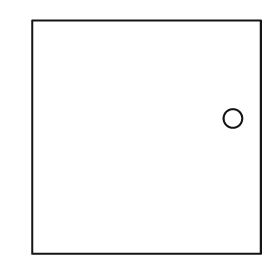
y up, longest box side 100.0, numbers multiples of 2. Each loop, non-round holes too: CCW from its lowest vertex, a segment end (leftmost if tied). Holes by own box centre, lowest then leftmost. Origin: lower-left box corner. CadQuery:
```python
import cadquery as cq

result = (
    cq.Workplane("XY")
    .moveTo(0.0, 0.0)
    .lineTo(98.0, 0.0)
    .lineTo(98.0, 100.0)
    .lineTo(0.0, 100.0)
    .close()
    .moveTo(86.0, 58.0)
    .circle(4.0)
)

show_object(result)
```